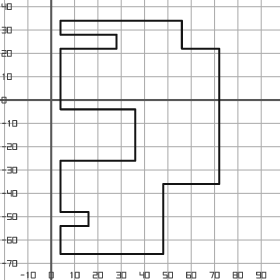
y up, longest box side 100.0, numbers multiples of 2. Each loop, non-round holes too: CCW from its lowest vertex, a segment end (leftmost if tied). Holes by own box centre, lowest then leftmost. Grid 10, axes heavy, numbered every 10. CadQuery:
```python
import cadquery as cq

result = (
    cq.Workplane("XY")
    .moveTo(4.0, -66.0)
    .lineTo(48.0, -66.0)
    .lineTo(48.0, -36.0)
    .lineTo(72.0, -36.0)
    .lineTo(72.0, 22.0)
    .lineTo(56.0, 22.0)
    .lineTo(56.0, 34.0)
    .lineTo(4.0, 34.0)
    .lineTo(4.0, 28.0)
    .lineTo(28.0, 28.0)
    .lineTo(28.0, 22.0)
    .lineTo(4.0, 22.0)
    .lineTo(4.0, -4.0)
    .lineTo(36.0, -4.0)
    .lineTo(36.0, -26.0)
    .lineTo(4.0, -26.0)
    .lineTo(4.0, -48.0)
    .lineTo(16.0, -48.0)
    .lineTo(16.0, -54.0)
    .lineTo(4.0, -54.0)
    .close()
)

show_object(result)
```